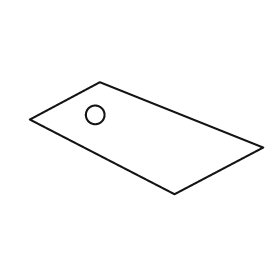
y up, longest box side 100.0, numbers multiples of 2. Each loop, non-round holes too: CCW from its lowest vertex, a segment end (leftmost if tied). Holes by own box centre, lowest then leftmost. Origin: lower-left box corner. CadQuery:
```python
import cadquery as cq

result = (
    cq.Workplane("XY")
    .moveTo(62.0, 0.0)
    .lineTo(100.0, 20.0)
    .lineTo(30.0, 48.0)
    .lineTo(0.0, 32.0)
    .close()
    .moveTo(28.0, 34.0)
    .circle(4.0)
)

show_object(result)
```